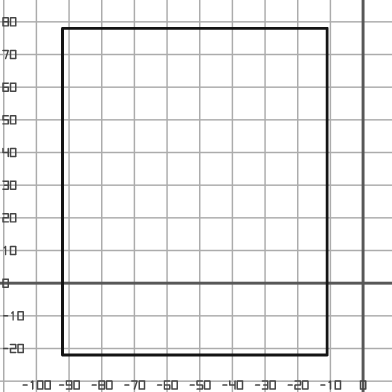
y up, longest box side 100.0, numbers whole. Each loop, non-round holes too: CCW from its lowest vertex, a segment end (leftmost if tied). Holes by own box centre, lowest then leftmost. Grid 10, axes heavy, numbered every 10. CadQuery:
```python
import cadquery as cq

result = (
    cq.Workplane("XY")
    .moveTo(-92.0, -22.0)
    .lineTo(-11.0, -22.0)
    .lineTo(-11.0, 78.0)
    .lineTo(-92.0, 78.0)
    .close()
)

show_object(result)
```